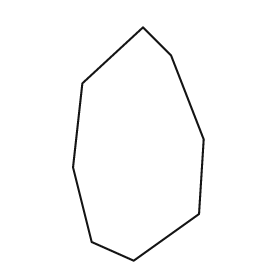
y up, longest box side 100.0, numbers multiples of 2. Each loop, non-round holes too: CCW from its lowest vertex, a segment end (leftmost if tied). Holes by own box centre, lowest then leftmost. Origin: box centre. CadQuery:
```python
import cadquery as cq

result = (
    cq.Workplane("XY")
    .moveTo(-2.0, -50.0)
    .lineTo(26.0, -30.0)
    .lineTo(28.0, 2.0)
    .lineTo(14.0, 38.0)
    .lineTo(2.0, 50.0)
    .lineTo(-24.0, 26.0)
    .lineTo(-28.0, -10.0)
    .lineTo(-20.0, -42.0)
    .close()
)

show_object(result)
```